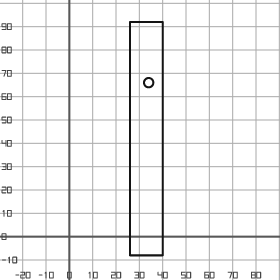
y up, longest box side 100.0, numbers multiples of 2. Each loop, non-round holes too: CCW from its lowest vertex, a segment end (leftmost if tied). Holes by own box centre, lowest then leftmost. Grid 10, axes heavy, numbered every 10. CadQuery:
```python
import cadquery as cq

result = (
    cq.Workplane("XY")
    .moveTo(26.0, -8.0)
    .lineTo(40.0, -8.0)
    .lineTo(40.0, 92.0)
    .lineTo(26.0, 92.0)
    .close()
    .moveTo(34.0, 66.0)
    .circle(2.0)
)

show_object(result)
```